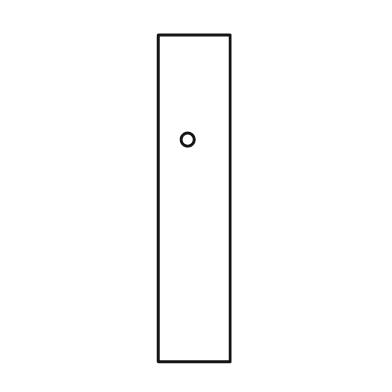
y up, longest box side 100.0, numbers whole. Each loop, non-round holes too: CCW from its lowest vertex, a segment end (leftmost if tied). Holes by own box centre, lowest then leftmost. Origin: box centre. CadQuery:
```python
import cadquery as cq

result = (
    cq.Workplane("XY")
    .moveTo(-11.0, -50.0)
    .lineTo(11.0, -50.0)
    .lineTo(11.0, 50.0)
    .lineTo(-11.0, 50.0)
    .close()
    .moveTo(-2.0, 18.0)
    .circle(2.0)
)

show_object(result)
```